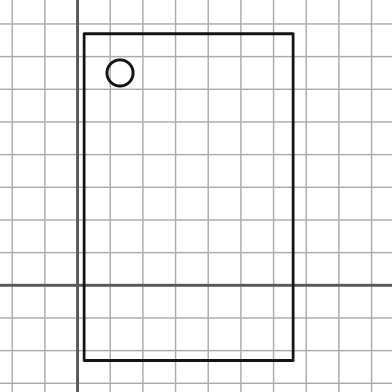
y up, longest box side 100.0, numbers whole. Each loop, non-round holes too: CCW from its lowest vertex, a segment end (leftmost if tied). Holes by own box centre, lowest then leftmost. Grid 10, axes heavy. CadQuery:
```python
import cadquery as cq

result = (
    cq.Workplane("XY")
    .moveTo(2.0, -23.0)
    .lineTo(66.0, -23.0)
    .lineTo(66.0, 77.0)
    .lineTo(2.0, 77.0)
    .close()
    .moveTo(13.0, 65.0)
    .circle(4.0)
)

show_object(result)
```